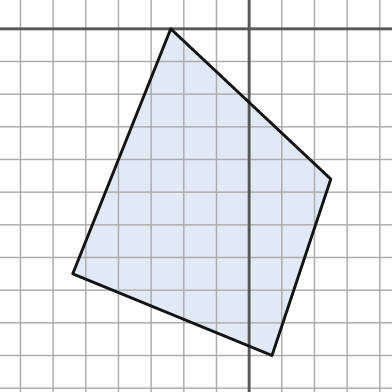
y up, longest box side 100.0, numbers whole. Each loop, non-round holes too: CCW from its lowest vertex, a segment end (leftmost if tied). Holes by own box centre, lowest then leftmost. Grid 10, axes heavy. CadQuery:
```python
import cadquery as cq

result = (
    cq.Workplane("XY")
    .moveTo(7.0, -100.0)
    .lineTo(25.0, -46.0)
    .lineTo(-24.0, 0.0)
    .lineTo(-54.0, -75.0)
    .close()
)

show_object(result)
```